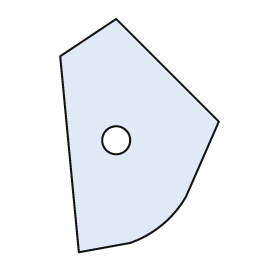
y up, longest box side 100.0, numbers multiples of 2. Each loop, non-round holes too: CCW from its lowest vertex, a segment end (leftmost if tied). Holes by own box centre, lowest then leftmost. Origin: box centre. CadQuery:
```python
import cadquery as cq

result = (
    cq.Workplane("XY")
    .moveTo(-26.0, -50.0)
    .lineTo(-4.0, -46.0)
    .threePointArc((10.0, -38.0), (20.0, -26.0))
    .lineTo(34.0, 6.0)
    .lineTo(-10.0, 50.0)
    .lineTo(-34.0, 34.0)
    .close()
    .moveTo(-10.0, -2.0)
    .circle(6.0)
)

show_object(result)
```